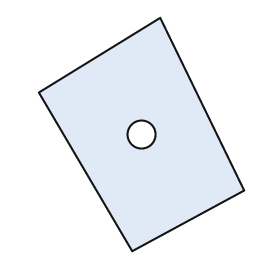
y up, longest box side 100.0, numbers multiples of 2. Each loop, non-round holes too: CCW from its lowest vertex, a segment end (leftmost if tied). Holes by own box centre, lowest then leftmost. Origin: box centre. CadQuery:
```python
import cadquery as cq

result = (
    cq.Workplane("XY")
    .moveTo(-4.0, -50.0)
    .lineTo(44.0, -24.0)
    .lineTo(8.0, 50.0)
    .lineTo(-44.0, 18.0)
    .close()
    .moveTo(0.0, 0.0)
    .circle(6.0)
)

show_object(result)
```